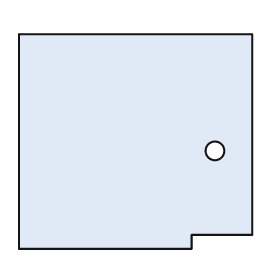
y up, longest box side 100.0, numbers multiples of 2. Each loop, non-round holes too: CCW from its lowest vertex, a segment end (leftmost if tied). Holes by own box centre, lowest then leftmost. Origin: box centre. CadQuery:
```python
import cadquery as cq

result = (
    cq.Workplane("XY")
    .moveTo(-50.0, -46.0)
    .lineTo(24.0, -46.0)
    .lineTo(24.0, -40.0)
    .lineTo(50.0, -40.0)
    .lineTo(50.0, 46.0)
    .lineTo(-50.0, 46.0)
    .close()
    .moveTo(34.0, -4.0)
    .circle(4.0)
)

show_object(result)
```